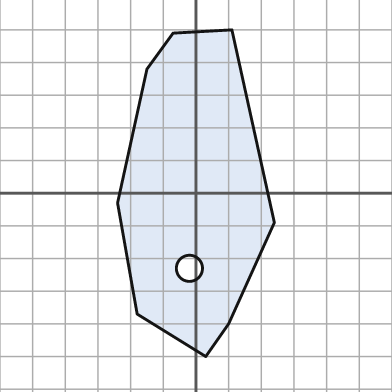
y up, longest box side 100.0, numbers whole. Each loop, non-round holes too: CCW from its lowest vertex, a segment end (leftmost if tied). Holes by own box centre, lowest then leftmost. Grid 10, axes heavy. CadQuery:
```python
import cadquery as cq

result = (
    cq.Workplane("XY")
    .moveTo(3.0, -50.0)
    .lineTo(10.0, -40.0)
    .lineTo(24.0, -9.0)
    .lineTo(11.0, 50.0)
    .lineTo(-7.0, 49.0)
    .lineTo(-15.0, 38.0)
    .lineTo(-24.0, -3.0)
    .lineTo(-18.0, -37.0)
    .close()
    .moveTo(-2.0, -23.0)
    .circle(4.0)
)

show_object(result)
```